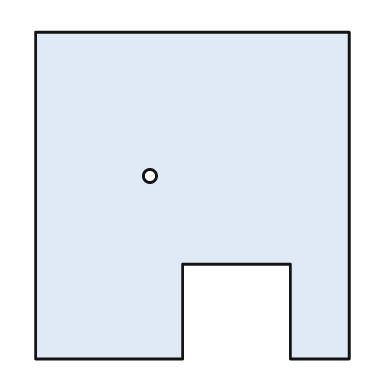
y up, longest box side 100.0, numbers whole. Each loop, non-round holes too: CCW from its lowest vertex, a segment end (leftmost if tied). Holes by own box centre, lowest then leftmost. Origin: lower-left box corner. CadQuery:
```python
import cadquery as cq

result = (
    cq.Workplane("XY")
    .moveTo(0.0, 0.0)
    .lineTo(45.0, 0.0)
    .lineTo(45.0, 29.0)
    .lineTo(78.0, 29.0)
    .lineTo(78.0, 0.0)
    .lineTo(96.0, 0.0)
    .lineTo(96.0, 100.0)
    .lineTo(0.0, 100.0)
    .close()
    .moveTo(35.0, 56.0)
    .circle(2.0)
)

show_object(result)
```